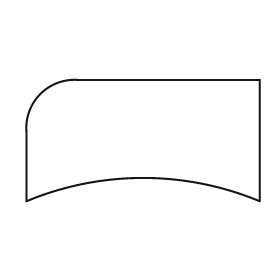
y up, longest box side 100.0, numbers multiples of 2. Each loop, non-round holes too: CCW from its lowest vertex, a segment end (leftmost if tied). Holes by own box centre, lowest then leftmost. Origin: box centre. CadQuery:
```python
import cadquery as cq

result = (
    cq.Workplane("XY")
    .moveTo(-50.0, -26.0)
    .threePointArc((0.0, -16.0), (50.0, -26.0))
    .lineTo(50.0, 26.0)
    .lineTo(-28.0, 26.0)
    .threePointArc((-44.0, 20.0), (-50.0, 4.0))
    .close()
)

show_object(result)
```